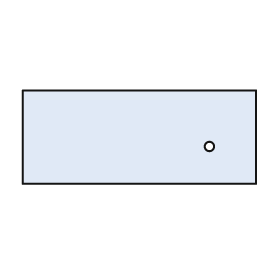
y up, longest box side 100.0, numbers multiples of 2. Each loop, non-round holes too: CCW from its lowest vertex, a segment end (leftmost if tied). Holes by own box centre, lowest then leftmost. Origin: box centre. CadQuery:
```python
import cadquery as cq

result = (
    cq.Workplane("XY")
    .moveTo(-50.0, -20.0)
    .lineTo(50.0, -20.0)
    .lineTo(50.0, 20.0)
    .lineTo(-50.0, 20.0)
    .close()
    .moveTo(30.0, -4.0)
    .circle(2.0)
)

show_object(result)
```